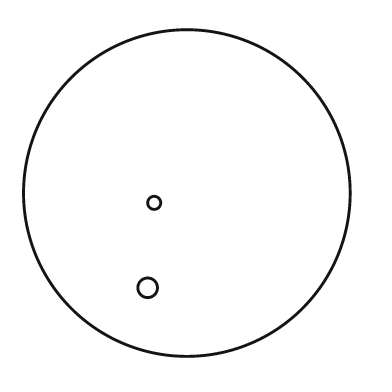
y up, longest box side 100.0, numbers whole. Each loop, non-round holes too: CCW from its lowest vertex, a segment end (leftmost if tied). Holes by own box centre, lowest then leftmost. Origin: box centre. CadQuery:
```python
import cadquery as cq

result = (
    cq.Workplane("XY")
    .moveTo(0.0, 0.0)
    .circle(50.0)
    .moveTo(-12.0, -29.0)
    .circle(3.0)
    .moveTo(-10.0, -3.0)
    .circle(2.0)
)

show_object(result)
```